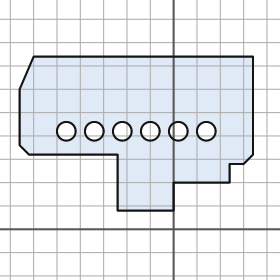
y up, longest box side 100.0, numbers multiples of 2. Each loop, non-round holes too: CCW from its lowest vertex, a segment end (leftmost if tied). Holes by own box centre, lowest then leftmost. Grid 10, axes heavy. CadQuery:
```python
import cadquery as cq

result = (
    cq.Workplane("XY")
    .moveTo(-24.0, 8.0)
    .lineTo(0.0, 8.0)
    .lineTo(0.0, 20.0)
    .lineTo(24.0, 20.0)
    .lineTo(24.0, 28.0)
    .lineTo(30.0, 28.0)
    .lineTo(34.0, 32.0)
    .lineTo(34.0, 74.0)
    .lineTo(-60.0, 74.0)
    .lineTo(-66.0, 60.0)
    .lineTo(-66.0, 36.0)
    .lineTo(-62.0, 32.0)
    .lineTo(-24.0, 32.0)
    .close()
    .moveTo(-46.0, 42.0)
    .circle(4.0)
    .moveTo(-34.0, 42.0)
    .circle(4.0)
    .moveTo(-22.0, 42.0)
    .circle(4.0)
    .moveTo(-10.0, 42.0)
    .circle(4.0)
    .moveTo(2.0, 42.0)
    .circle(4.0)
    .moveTo(14.0, 42.0)
    .circle(4.0)
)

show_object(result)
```